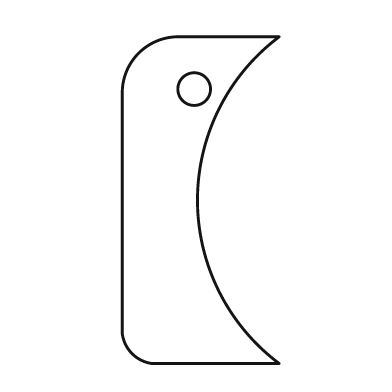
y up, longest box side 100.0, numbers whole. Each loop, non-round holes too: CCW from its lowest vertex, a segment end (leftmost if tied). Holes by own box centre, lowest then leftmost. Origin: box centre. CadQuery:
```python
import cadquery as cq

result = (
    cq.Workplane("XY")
    .moveTo(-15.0, -50.0)
    .lineTo(24.0, -50.0)
    .threePointArc((-1.0, 0.0), (24.0, 50.0))
    .lineTo(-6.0, 50.0)
    .threePointArc((-19.0, 45.0), (-24.0, 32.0))
    .lineTo(-24.0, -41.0)
    .threePointArc((-21.0, -47.0), (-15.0, -50.0))
    .close()
    .moveTo(-2.0, 34.0)
    .circle(5.0)
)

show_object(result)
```